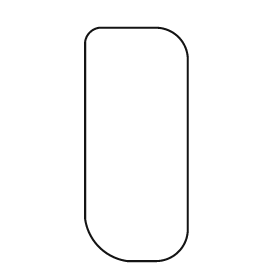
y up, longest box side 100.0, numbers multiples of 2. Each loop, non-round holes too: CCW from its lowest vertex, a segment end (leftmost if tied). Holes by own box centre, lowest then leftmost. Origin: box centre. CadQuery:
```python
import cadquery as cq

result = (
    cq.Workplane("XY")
    .moveTo(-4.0, -50.0)
    .lineTo(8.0, -50.0)
    .threePointArc((18.0, -46.0), (22.0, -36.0))
    .lineTo(22.0, 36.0)
    .threePointArc((18.0, 46.0), (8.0, 50.0))
    .lineTo(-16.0, 50.0)
    .threePointArc((-20.0, 48.0), (-22.0, 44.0))
    .lineTo(-22.0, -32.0)
    .threePointArc((-16.0, -44.0), (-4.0, -50.0))
    .close()
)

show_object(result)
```